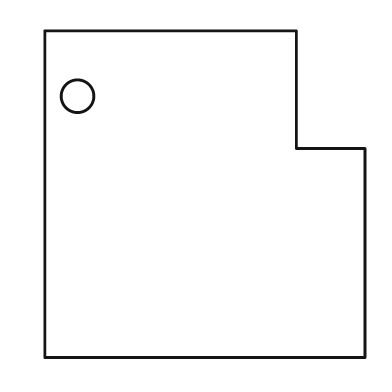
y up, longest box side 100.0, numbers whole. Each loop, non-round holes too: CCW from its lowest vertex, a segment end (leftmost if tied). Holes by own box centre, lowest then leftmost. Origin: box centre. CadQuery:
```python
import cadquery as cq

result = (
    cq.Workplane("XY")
    .moveTo(-49.0, -50.0)
    .lineTo(49.0, -50.0)
    .lineTo(49.0, 14.0)
    .lineTo(28.0, 14.0)
    .lineTo(28.0, 50.0)
    .lineTo(-49.0, 50.0)
    .close()
    .moveTo(-39.0, 30.0)
    .circle(5.0)
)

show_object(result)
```